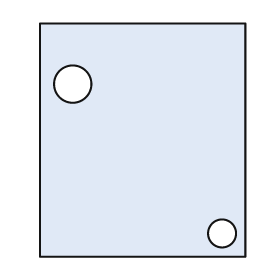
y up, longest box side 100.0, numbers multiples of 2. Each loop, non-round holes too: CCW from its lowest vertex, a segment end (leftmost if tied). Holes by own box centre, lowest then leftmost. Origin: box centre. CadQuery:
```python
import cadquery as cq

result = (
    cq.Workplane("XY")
    .moveTo(-44.0, -50.0)
    .lineTo(44.0, -50.0)
    .lineTo(44.0, 50.0)
    .lineTo(-44.0, 50.0)
    .close()
    .moveTo(34.0, -40.0)
    .circle(6.0)
    .moveTo(-30.0, 24.0)
    .circle(8.0)
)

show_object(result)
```